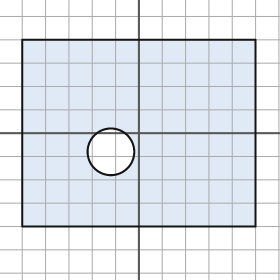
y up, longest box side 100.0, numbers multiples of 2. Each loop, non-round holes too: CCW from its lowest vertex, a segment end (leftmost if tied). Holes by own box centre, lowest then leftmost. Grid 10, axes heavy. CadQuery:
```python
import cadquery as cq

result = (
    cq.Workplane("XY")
    .moveTo(-50.0, -40.0)
    .lineTo(50.0, -40.0)
    .lineTo(50.0, 40.0)
    .lineTo(-50.0, 40.0)
    .close()
    .moveTo(-12.0, -8.0)
    .circle(10.0)
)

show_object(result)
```